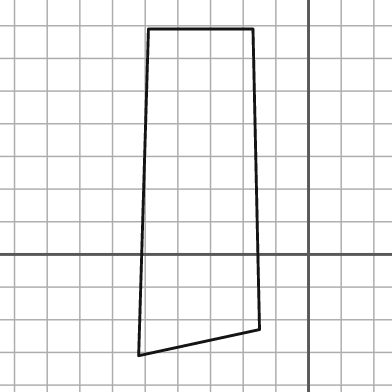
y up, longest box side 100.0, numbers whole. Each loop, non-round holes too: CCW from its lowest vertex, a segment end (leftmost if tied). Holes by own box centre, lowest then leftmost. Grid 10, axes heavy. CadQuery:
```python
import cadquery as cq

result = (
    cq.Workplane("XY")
    .moveTo(-52.0, -31.0)
    .lineTo(-15.0, -23.0)
    .lineTo(-17.0, 69.0)
    .lineTo(-49.0, 69.0)
    .close()
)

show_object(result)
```